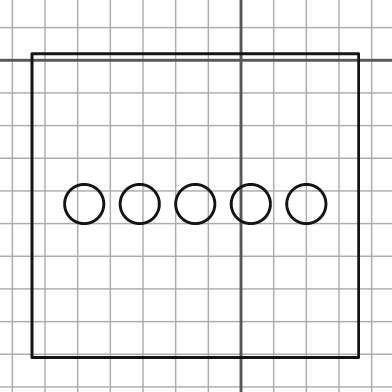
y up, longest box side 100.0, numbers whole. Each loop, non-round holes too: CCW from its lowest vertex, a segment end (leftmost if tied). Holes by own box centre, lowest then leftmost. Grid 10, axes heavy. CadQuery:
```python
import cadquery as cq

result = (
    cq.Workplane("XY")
    .moveTo(-64.0, -91.0)
    .lineTo(36.0, -91.0)
    .lineTo(36.0, 2.0)
    .lineTo(-64.0, 2.0)
    .close()
    .moveTo(-48.0, -44.0)
    .circle(6.0)
    .moveTo(-31.0, -44.0)
    .circle(6.0)
    .moveTo(-14.0, -44.0)
    .circle(6.0)
    .moveTo(3.0, -44.0)
    .circle(6.0)
    .moveTo(20.0, -44.0)
    .circle(6.0)
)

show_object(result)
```